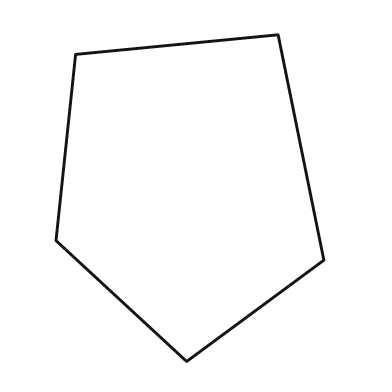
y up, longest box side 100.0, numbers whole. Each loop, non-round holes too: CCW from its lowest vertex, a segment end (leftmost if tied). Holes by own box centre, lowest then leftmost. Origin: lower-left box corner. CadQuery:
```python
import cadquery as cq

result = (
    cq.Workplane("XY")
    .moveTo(40.0, 0.0)
    .lineTo(82.0, 31.0)
    .lineTo(68.0, 100.0)
    .lineTo(6.0, 94.0)
    .lineTo(0.0, 37.0)
    .close()
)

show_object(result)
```